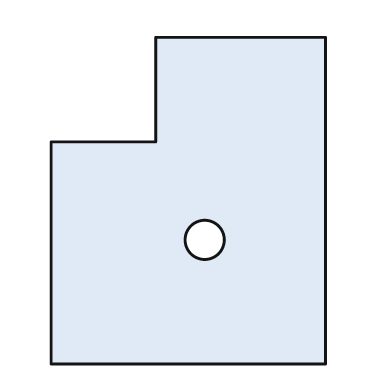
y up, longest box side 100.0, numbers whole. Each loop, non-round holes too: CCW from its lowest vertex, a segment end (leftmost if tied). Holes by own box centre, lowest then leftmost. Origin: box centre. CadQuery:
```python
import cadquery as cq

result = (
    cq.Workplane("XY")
    .moveTo(-42.0, -50.0)
    .lineTo(42.0, -50.0)
    .lineTo(42.0, 50.0)
    .lineTo(-10.0, 50.0)
    .lineTo(-10.0, 18.0)
    .lineTo(-42.0, 18.0)
    .close()
    .moveTo(5.0, -12.0)
    .circle(6.0)
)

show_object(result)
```